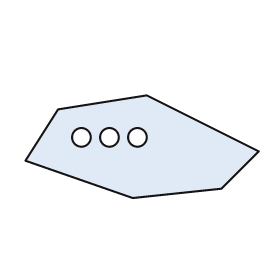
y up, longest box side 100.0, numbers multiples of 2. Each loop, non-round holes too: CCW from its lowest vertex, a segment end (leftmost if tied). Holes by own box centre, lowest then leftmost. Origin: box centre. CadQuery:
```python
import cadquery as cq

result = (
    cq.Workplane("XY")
    .moveTo(-4.0, -22.0)
    .lineTo(34.0, -18.0)
    .lineTo(50.0, -2.0)
    .lineTo(2.0, 22.0)
    .lineTo(-36.0, 16.0)
    .lineTo(-50.0, -6.0)
    .close()
    .moveTo(-26.0, 4.0)
    .circle(4.0)
    .moveTo(-14.0, 4.0)
    .circle(4.0)
    .moveTo(-2.0, 4.0)
    .circle(4.0)
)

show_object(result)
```